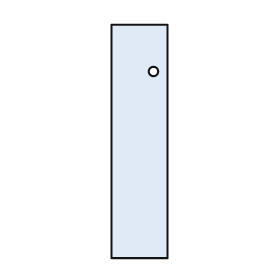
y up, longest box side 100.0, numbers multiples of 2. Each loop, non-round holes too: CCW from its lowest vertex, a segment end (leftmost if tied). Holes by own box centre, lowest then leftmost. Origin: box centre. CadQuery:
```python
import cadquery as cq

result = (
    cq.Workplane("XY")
    .moveTo(-12.0, -50.0)
    .lineTo(12.0, -50.0)
    .lineTo(12.0, 50.0)
    .lineTo(-12.0, 50.0)
    .close()
    .moveTo(6.0, 30.0)
    .circle(2.0)
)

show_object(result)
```